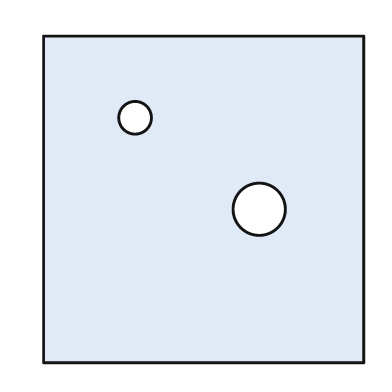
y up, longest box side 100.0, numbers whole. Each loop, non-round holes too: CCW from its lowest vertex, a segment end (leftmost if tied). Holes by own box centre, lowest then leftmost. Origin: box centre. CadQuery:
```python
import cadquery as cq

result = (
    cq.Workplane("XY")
    .moveTo(-49.0, -50.0)
    .lineTo(49.0, -50.0)
    .lineTo(49.0, 50.0)
    .lineTo(-49.0, 50.0)
    .close()
    .moveTo(17.0, -3.0)
    .circle(8.0)
    .moveTo(-21.0, 25.0)
    .circle(5.0)
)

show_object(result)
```